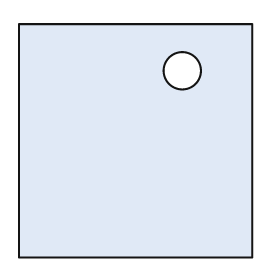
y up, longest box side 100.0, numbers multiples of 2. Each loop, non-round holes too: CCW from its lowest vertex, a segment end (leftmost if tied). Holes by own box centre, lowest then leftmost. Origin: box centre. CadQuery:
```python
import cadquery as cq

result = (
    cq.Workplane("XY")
    .moveTo(-50.0, -50.0)
    .lineTo(50.0, -50.0)
    .lineTo(50.0, 50.0)
    .lineTo(-50.0, 50.0)
    .close()
    .moveTo(20.0, 30.0)
    .circle(8.0)
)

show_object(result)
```